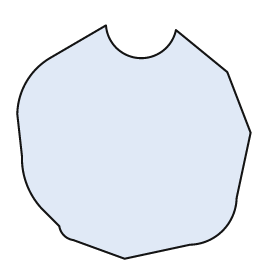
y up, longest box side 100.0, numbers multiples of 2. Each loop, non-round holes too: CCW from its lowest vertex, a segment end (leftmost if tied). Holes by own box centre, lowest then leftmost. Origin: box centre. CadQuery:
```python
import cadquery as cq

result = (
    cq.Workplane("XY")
    .moveTo(-4.0, -50.0)
    .lineTo(24.0, -44.0)
    .threePointArc((38.0, -38.0), (44.0, -24.0))
    .lineTo(50.0, 4.0)
    .lineTo(40.0, 30.0)
    .lineTo(18.0, 48.0)
    .threePointArc((2.0, 36.0), (-12.0, 50.0))
    .lineTo(-36.0, 36.0)
    .threePointArc((-46.0, 26.0), (-50.0, 12.0))
    .lineTo(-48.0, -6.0)
    .threePointArc((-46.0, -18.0), (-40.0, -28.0))
    .lineTo(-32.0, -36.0)
    .threePointArc((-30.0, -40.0), (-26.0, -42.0))
    .close()
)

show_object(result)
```